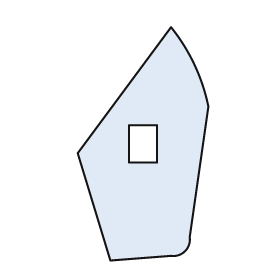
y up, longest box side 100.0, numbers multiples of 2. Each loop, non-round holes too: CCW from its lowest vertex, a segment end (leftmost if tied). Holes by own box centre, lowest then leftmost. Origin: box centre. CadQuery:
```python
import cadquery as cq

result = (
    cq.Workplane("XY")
    .moveTo(-14.0, -50.0)
    .lineTo(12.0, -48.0)
    .threePointArc((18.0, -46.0), (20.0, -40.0))
    .lineTo(28.0, 16.0)
    .threePointArc((22.0, 34.0), (12.0, 50.0))
    .lineTo(-28.0, -4.0)
    .close()
    .moveTo(-6.0, -8.0)
    .lineTo(6.0, -8.0)
    .lineTo(6.0, 8.0)
    .lineTo(-6.0, 8.0)
    .close()
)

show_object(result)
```